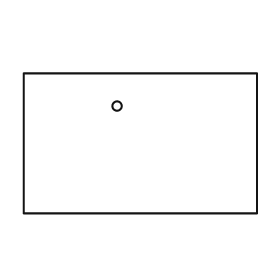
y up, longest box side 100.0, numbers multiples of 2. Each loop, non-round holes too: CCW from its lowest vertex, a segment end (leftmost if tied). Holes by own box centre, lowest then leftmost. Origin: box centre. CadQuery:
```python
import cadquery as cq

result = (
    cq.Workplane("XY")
    .moveTo(-50.0, -30.0)
    .lineTo(50.0, -30.0)
    .lineTo(50.0, 30.0)
    .lineTo(-50.0, 30.0)
    .close()
    .moveTo(-10.0, 16.0)
    .circle(2.0)
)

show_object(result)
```